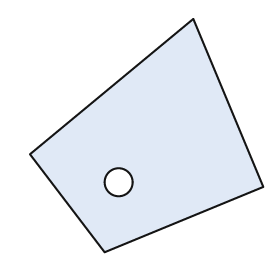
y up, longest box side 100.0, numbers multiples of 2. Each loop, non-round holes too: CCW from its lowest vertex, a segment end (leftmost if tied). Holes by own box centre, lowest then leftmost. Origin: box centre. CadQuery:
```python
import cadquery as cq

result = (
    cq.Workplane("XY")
    .moveTo(-18.0, -50.0)
    .lineTo(50.0, -22.0)
    .lineTo(20.0, 50.0)
    .lineTo(-50.0, -8.0)
    .close()
    .moveTo(-12.0, -20.0)
    .circle(6.0)
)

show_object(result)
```